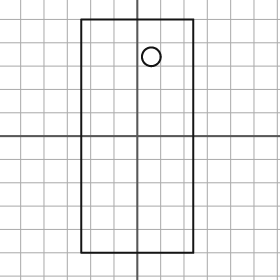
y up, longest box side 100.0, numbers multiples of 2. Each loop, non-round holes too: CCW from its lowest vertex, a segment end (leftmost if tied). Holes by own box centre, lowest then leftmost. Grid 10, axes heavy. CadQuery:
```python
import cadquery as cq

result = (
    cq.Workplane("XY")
    .moveTo(-24.0, -50.0)
    .lineTo(24.0, -50.0)
    .lineTo(24.0, 50.0)
    .lineTo(-24.0, 50.0)
    .close()
    .moveTo(6.0, 34.0)
    .circle(4.0)
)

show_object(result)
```